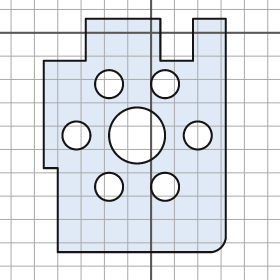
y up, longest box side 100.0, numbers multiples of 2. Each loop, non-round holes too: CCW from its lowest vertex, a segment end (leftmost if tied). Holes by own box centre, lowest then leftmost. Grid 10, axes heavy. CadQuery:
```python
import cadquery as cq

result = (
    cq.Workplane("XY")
    .moveTo(-40.0, -94.0)
    .lineTo(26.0, -94.0)
    .threePointArc((30.0, -92.0), (32.0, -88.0))
    .lineTo(32.0, 6.0)
    .lineTo(18.0, 6.0)
    .lineTo(18.0, -12.0)
    .lineTo(4.0, -12.0)
    .lineTo(4.0, 6.0)
    .lineTo(-28.0, 6.0)
    .lineTo(-28.0, -12.0)
    .lineTo(-46.0, -12.0)
    .lineTo(-46.0, -58.0)
    .lineTo(-40.0, -58.0)
    .close()
    .moveTo(-18.0, -66.0)
    .circle(6.0)
    .moveTo(6.0, -66.0)
    .circle(6.0)
    .moveTo(-32.0, -44.0)
    .circle(6.0)
    .moveTo(-6.0, -44.0)
    .circle(12.0)
    .moveTo(20.0, -44.0)
    .circle(6.0)
    .moveTo(-18.0, -22.0)
    .circle(6.0)
    .moveTo(6.0, -22.0)
    .circle(6.0)
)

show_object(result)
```